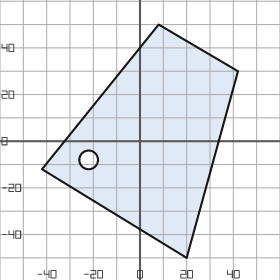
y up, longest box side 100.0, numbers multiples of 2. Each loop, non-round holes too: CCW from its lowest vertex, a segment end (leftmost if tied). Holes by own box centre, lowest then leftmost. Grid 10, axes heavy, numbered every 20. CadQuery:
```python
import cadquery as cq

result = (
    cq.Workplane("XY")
    .moveTo(20.0, -50.0)
    .lineTo(42.0, 30.0)
    .lineTo(8.0, 50.0)
    .lineTo(-42.0, -12.0)
    .close()
    .moveTo(-22.0, -8.0)
    .circle(4.0)
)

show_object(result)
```